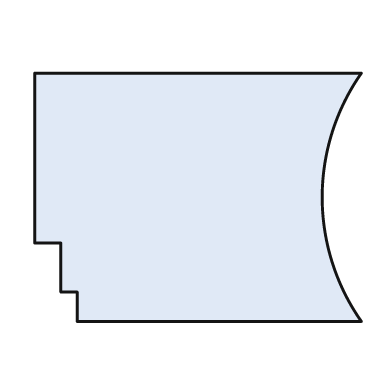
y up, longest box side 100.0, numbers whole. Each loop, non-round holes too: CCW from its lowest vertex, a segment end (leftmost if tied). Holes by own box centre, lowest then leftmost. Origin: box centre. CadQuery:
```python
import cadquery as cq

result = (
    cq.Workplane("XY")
    .moveTo(-37.0, -38.0)
    .lineTo(50.0, -38.0)
    .threePointArc((38.0, 0.0), (50.0, 38.0))
    .lineTo(-50.0, 38.0)
    .lineTo(-50.0, -14.0)
    .lineTo(-42.0, -14.0)
    .lineTo(-42.0, -29.0)
    .lineTo(-37.0, -29.0)
    .close()
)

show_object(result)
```